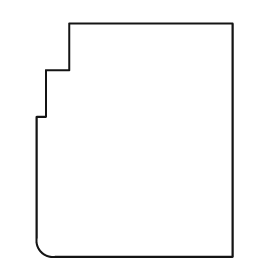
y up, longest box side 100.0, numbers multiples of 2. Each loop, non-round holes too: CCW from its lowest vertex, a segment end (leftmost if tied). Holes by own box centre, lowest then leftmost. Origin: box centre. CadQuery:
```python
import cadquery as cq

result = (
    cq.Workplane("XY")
    .moveTo(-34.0, -50.0)
    .lineTo(42.0, -50.0)
    .lineTo(42.0, 50.0)
    .lineTo(-28.0, 50.0)
    .lineTo(-28.0, 30.0)
    .lineTo(-38.0, 30.0)
    .lineTo(-38.0, 10.0)
    .lineTo(-42.0, 10.0)
    .lineTo(-42.0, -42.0)
    .threePointArc((-40.0, -48.0), (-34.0, -50.0))
    .close()
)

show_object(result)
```